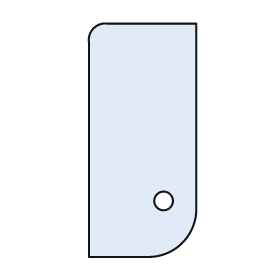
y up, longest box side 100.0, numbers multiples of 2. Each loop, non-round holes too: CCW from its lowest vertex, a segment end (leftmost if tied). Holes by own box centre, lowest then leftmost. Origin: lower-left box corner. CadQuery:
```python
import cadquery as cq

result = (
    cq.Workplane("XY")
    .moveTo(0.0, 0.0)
    .lineTo(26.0, 0.0)
    .threePointArc((40.0, 6.0), (46.0, 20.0))
    .lineTo(46.0, 100.0)
    .lineTo(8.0, 100.0)
    .threePointArc((2.0, 98.0), (0.0, 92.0))
    .close()
    .moveTo(32.0, 24.0)
    .circle(4.0)
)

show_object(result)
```